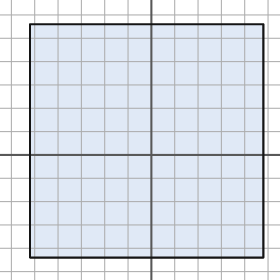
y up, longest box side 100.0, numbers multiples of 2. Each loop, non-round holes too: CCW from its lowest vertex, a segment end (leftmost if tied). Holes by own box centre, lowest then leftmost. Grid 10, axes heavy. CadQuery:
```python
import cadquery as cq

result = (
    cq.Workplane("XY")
    .moveTo(-52.0, -44.0)
    .lineTo(48.0, -44.0)
    .lineTo(48.0, 56.0)
    .lineTo(-52.0, 56.0)
    .close()
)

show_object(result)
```